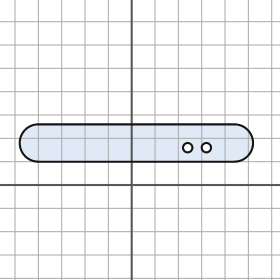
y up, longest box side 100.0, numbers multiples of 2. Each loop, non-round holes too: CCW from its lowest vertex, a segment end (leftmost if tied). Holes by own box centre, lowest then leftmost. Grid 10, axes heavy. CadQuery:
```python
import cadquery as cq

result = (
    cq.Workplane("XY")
    .moveTo(-40.0, 10.0)
    .lineTo(44.0, 10.0)
    .threePointArc((52.0, 18.0), (44.0, 26.0))
    .lineTo(-40.0, 26.0)
    .threePointArc((-48.0, 18.0), (-40.0, 10.0))
    .close()
    .moveTo(24.0, 16.0)
    .circle(2.0)
    .moveTo(32.0, 16.0)
    .circle(2.0)
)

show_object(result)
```